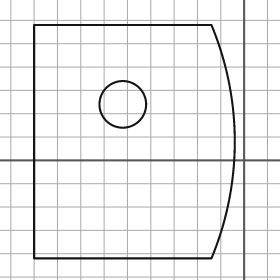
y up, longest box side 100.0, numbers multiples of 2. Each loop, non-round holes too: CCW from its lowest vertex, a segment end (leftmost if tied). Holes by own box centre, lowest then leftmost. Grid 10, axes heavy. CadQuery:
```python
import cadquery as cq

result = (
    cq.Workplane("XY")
    .moveTo(-90.0, -42.0)
    .lineTo(-14.0, -42.0)
    .threePointArc((-4.0, 8.0), (-14.0, 58.0))
    .lineTo(-90.0, 58.0)
    .close()
    .moveTo(-52.0, 24.0)
    .circle(10.0)
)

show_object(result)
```